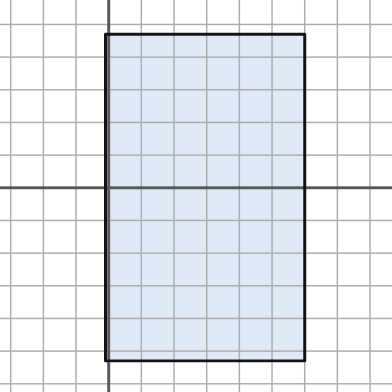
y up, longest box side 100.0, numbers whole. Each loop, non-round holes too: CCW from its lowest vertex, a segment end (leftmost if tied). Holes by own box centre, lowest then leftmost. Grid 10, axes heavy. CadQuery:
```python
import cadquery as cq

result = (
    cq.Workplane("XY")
    .moveTo(-1.0, -53.0)
    .lineTo(60.0, -53.0)
    .lineTo(60.0, 47.0)
    .lineTo(-1.0, 47.0)
    .close()
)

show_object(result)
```